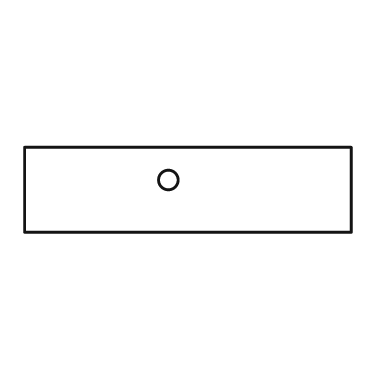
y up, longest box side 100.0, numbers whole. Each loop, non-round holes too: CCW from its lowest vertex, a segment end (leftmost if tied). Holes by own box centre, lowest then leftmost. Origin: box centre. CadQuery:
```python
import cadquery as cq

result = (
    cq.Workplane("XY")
    .moveTo(-50.0, -13.0)
    .lineTo(50.0, -13.0)
    .lineTo(50.0, 13.0)
    .lineTo(-50.0, 13.0)
    .close()
    .moveTo(-6.0, 3.0)
    .circle(3.0)
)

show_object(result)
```